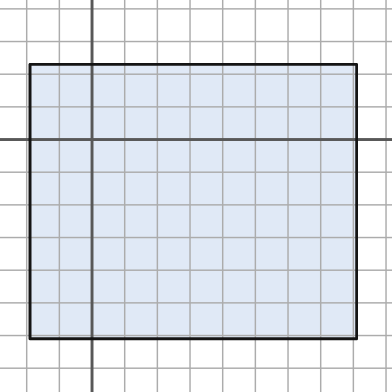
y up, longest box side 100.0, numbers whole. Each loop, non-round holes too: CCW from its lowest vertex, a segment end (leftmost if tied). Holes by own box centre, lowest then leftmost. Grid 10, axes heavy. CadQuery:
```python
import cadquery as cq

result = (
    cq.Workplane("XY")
    .moveTo(-19.0, -61.0)
    .lineTo(81.0, -61.0)
    .lineTo(81.0, 23.0)
    .lineTo(-19.0, 23.0)
    .close()
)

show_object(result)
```